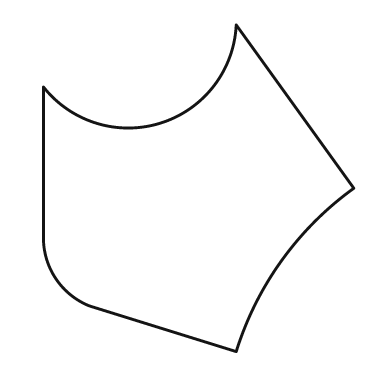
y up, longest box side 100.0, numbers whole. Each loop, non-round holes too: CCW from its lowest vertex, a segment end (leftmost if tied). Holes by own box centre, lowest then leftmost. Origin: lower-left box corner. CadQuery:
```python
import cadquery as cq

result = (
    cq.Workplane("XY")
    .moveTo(59.0, 0.0)
    .threePointArc((73.0, 28.0), (95.0, 50.0))
    .lineTo(59.0, 100.0)
    .threePointArc((36.0, 70.0), (0.0, 81.0))
    .lineTo(0.0, 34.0)
    .threePointArc((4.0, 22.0), (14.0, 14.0))
    .close()
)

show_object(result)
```